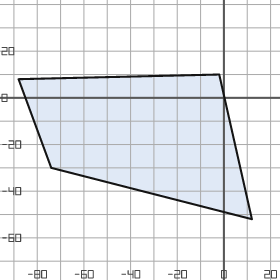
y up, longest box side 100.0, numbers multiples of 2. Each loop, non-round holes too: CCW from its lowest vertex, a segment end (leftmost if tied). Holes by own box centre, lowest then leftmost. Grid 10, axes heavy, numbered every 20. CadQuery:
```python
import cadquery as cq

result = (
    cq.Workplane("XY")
    .moveTo(12.0, -52.0)
    .lineTo(-2.0, 10.0)
    .lineTo(-88.0, 8.0)
    .lineTo(-74.0, -30.0)
    .close()
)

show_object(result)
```